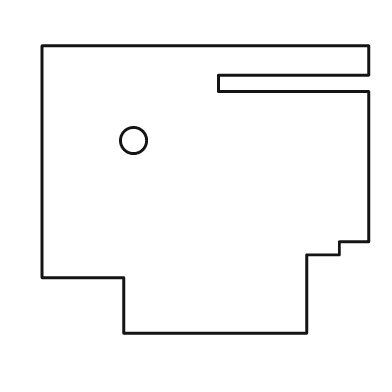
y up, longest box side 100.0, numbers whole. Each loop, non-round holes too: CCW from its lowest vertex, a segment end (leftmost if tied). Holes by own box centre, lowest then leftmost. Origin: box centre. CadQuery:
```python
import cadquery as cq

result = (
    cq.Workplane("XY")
    .moveTo(-25.0, -44.0)
    .lineTo(31.0, -44.0)
    .lineTo(31.0, -20.0)
    .lineTo(41.0, -20.0)
    .lineTo(41.0, -16.0)
    .lineTo(50.0, -16.0)
    .lineTo(50.0, 30.0)
    .lineTo(4.0, 30.0)
    .lineTo(4.0, 35.0)
    .lineTo(50.0, 35.0)
    .lineTo(50.0, 44.0)
    .lineTo(-50.0, 44.0)
    .lineTo(-50.0, -27.0)
    .lineTo(-25.0, -27.0)
    .close()
    .moveTo(-22.0, 15.0)
    .circle(4.0)
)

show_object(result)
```